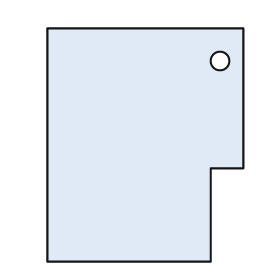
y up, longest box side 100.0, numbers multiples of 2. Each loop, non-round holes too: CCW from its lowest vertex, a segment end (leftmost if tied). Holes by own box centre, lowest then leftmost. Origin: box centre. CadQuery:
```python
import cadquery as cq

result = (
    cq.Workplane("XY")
    .moveTo(-42.0, -50.0)
    .lineTo(28.0, -50.0)
    .lineTo(28.0, -10.0)
    .lineTo(42.0, -10.0)
    .lineTo(42.0, 50.0)
    .lineTo(-42.0, 50.0)
    .close()
    .moveTo(32.0, 36.0)
    .circle(4.0)
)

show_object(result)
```